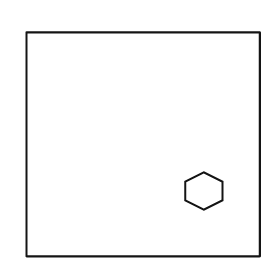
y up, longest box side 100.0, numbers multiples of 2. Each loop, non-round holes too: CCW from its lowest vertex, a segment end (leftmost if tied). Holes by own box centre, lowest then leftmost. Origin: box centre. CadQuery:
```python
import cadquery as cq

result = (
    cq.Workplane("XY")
    .moveTo(-50.0, -48.0)
    .lineTo(50.0, -48.0)
    .lineTo(50.0, 48.0)
    .lineTo(-50.0, 48.0)
    .close()
    .moveTo(26.0, -28.0)
    .lineTo(34.0, -24.0)
    .lineTo(34.0, -16.0)
    .lineTo(26.0, -12.0)
    .lineTo(18.0, -16.0)
    .lineTo(18.0, -24.0)
    .close()
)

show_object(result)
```